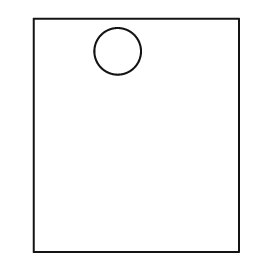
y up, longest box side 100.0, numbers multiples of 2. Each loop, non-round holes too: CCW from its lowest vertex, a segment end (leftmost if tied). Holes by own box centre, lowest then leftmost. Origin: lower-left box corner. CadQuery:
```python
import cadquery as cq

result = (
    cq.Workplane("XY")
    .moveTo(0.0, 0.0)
    .lineTo(88.0, 0.0)
    .lineTo(88.0, 100.0)
    .lineTo(0.0, 100.0)
    .close()
    .moveTo(36.0, 86.0)
    .circle(10.0)
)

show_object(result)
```